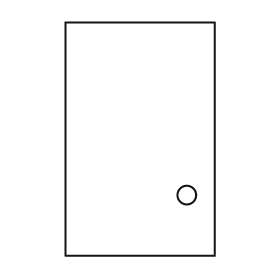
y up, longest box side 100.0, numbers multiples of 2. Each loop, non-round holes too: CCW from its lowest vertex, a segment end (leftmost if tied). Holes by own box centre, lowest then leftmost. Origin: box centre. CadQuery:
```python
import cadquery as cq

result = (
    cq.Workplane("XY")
    .moveTo(-32.0, -50.0)
    .lineTo(32.0, -50.0)
    .lineTo(32.0, 50.0)
    .lineTo(-32.0, 50.0)
    .close()
    .moveTo(20.0, -24.0)
    .circle(4.0)
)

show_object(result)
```